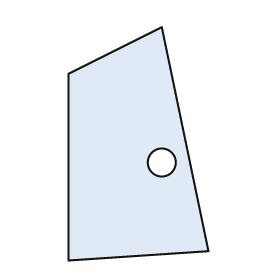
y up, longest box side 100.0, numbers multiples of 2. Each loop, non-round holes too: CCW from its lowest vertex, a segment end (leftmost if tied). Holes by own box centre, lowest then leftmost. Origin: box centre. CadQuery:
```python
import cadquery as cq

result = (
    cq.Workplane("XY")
    .moveTo(-30.0, -50.0)
    .lineTo(30.0, -46.0)
    .lineTo(10.0, 50.0)
    .lineTo(-30.0, 30.0)
    .close()
    .moveTo(10.0, -8.0)
    .circle(6.0)
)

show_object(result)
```